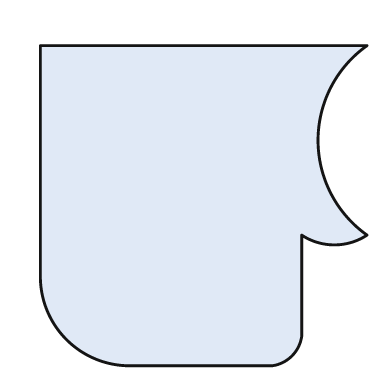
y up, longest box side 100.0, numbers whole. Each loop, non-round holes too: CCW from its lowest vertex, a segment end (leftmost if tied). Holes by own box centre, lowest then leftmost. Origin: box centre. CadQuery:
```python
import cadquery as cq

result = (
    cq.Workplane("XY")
    .moveTo(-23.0, -49.0)
    .lineTo(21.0, -49.0)
    .threePointArc((27.0, -46.0), (30.0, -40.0))
    .lineTo(30.0, -9.0)
    .threePointArc((40.0, -12.0), (50.0, -9.0))
    .threePointArc((35.0, 20.0), (50.0, 49.0))
    .lineTo(-50.0, 49.0)
    .lineTo(-50.0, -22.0)
    .threePointArc((-42.0, -41.0), (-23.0, -49.0))
    .close()
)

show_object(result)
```